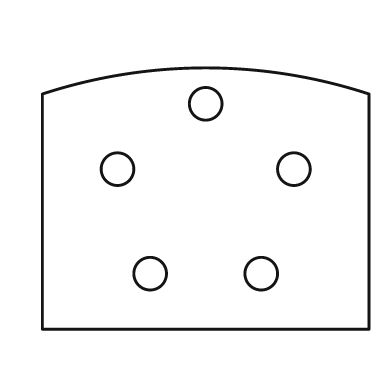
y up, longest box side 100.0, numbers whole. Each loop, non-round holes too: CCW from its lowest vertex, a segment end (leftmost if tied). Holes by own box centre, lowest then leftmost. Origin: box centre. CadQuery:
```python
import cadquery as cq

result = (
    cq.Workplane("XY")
    .moveTo(-50.0, -40.0)
    .lineTo(50.0, -40.0)
    .lineTo(50.0, 32.0)
    .threePointArc((0.0, 40.0), (-50.0, 32.0))
    .close()
    .moveTo(-17.0, -23.0)
    .circle(5.0)
    .moveTo(17.0, -23.0)
    .circle(5.0)
    .moveTo(-27.0, 9.0)
    .circle(5.0)
    .moveTo(27.0, 9.0)
    .circle(5.0)
    .moveTo(0.0, 29.0)
    .circle(5.0)
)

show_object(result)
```